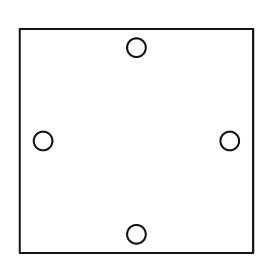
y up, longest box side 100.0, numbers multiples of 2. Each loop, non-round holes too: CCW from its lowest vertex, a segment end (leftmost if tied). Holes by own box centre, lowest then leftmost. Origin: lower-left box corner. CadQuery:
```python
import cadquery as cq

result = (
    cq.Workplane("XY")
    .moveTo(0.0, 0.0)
    .lineTo(100.0, 0.0)
    .lineTo(100.0, 96.0)
    .lineTo(0.0, 96.0)
    .close()
    .moveTo(50.0, 8.0)
    .circle(4.0)
    .moveTo(10.0, 48.0)
    .circle(4.0)
    .moveTo(90.0, 48.0)
    .circle(4.0)
    .moveTo(50.0, 88.0)
    .circle(4.0)
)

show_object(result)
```